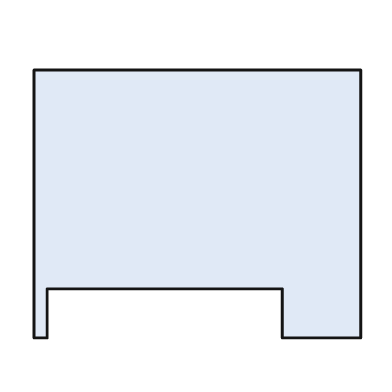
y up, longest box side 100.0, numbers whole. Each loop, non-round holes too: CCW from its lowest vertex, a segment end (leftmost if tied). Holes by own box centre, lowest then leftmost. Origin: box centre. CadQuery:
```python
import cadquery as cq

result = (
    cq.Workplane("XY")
    .moveTo(-50.0, -41.0)
    .lineTo(-46.0, -41.0)
    .lineTo(-46.0, -26.0)
    .lineTo(26.0, -26.0)
    .lineTo(26.0, -41.0)
    .lineTo(50.0, -41.0)
    .lineTo(50.0, 41.0)
    .lineTo(-50.0, 41.0)
    .close()
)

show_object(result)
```